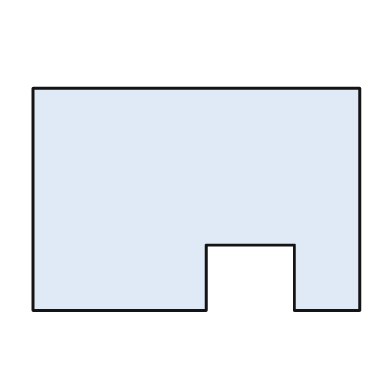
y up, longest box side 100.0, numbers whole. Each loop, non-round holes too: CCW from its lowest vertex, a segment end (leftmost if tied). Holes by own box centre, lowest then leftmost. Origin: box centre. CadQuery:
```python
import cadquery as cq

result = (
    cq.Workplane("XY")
    .moveTo(-50.0, -34.0)
    .lineTo(3.0, -34.0)
    .lineTo(3.0, -14.0)
    .lineTo(30.0, -14.0)
    .lineTo(30.0, -34.0)
    .lineTo(50.0, -34.0)
    .lineTo(50.0, 34.0)
    .lineTo(-50.0, 34.0)
    .close()
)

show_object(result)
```